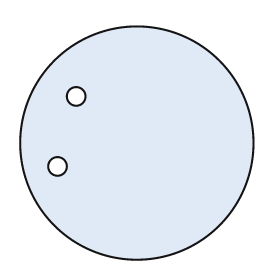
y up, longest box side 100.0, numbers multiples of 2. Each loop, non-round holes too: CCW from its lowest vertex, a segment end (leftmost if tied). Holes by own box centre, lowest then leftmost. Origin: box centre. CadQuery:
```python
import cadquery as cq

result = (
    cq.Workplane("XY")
    .moveTo(0.0, 0.0)
    .circle(50.0)
    .moveTo(-34.0, -10.0)
    .circle(4.0)
    .moveTo(-26.0, 20.0)
    .circle(4.0)
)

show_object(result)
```